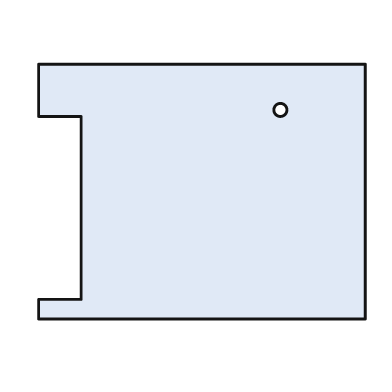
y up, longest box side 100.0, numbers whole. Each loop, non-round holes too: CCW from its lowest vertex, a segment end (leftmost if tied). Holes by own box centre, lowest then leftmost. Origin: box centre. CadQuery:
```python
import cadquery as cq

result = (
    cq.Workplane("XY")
    .moveTo(-50.0, -39.0)
    .lineTo(50.0, -39.0)
    .lineTo(50.0, 39.0)
    .lineTo(-50.0, 39.0)
    .lineTo(-50.0, 23.0)
    .lineTo(-37.0, 23.0)
    .lineTo(-37.0, -33.0)
    .lineTo(-50.0, -33.0)
    .close()
    .moveTo(24.0, 25.0)
    .circle(2.0)
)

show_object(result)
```